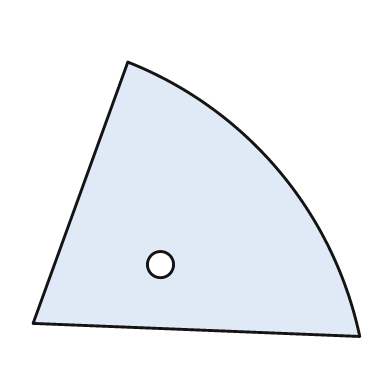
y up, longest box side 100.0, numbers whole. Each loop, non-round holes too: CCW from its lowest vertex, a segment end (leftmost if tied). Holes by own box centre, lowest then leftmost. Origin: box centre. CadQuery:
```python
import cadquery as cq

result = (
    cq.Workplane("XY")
    .moveTo(50.0, -42.0)
    .threePointArc((25.0, 9.0), (-21.0, 42.0))
    .lineTo(-50.0, -38.0)
    .close()
    .moveTo(-11.0, -20.0)
    .circle(4.0)
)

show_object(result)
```